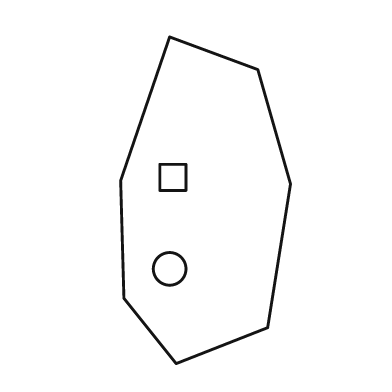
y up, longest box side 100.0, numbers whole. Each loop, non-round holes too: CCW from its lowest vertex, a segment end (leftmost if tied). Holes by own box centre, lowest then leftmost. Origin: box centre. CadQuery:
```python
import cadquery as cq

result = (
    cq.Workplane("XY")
    .moveTo(-9.0, -50.0)
    .lineTo(19.0, -39.0)
    .lineTo(26.0, 5.0)
    .lineTo(16.0, 40.0)
    .lineTo(-11.0, 50.0)
    .lineTo(-26.0, 6.0)
    .lineTo(-25.0, -30.0)
    .close()
    .moveTo(-11.0, -21.0)
    .circle(5.0)
    .moveTo(-14.0, 3.0)
    .lineTo(-6.0, 3.0)
    .lineTo(-6.0, 11.0)
    .lineTo(-14.0, 11.0)
    .close()
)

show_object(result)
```